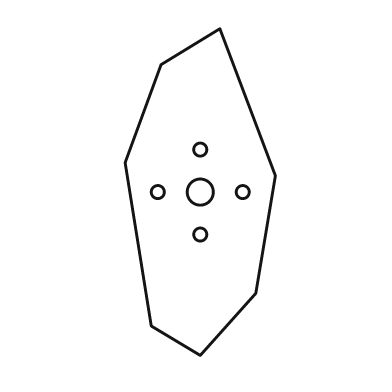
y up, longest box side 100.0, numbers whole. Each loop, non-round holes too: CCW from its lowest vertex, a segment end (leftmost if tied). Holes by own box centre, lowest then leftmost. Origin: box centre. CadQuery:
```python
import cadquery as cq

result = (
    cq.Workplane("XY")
    .moveTo(0.0, -50.0)
    .lineTo(17.0, -31.0)
    .lineTo(23.0, 5.0)
    .lineTo(6.0, 50.0)
    .lineTo(-12.0, 39.0)
    .lineTo(-23.0, 9.0)
    .lineTo(-15.0, -41.0)
    .close()
    .moveTo(0.0, -13.0)
    .circle(2.0)
    .moveTo(-13.0, 0.0)
    .circle(2.0)
    .moveTo(0.0, 0.0)
    .circle(4.0)
    .moveTo(13.0, 0.0)
    .circle(2.0)
    .moveTo(0.0, 13.0)
    .circle(2.0)
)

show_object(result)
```